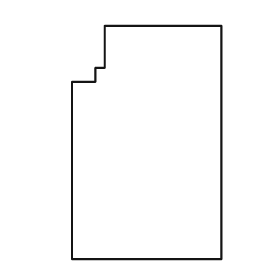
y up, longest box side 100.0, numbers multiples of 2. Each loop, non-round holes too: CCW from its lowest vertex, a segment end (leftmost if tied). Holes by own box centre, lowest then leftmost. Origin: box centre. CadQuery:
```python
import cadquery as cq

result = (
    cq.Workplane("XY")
    .moveTo(-32.0, -50.0)
    .lineTo(32.0, -50.0)
    .lineTo(32.0, 50.0)
    .lineTo(-18.0, 50.0)
    .lineTo(-18.0, 32.0)
    .lineTo(-22.0, 32.0)
    .lineTo(-22.0, 26.0)
    .lineTo(-32.0, 26.0)
    .close()
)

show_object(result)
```